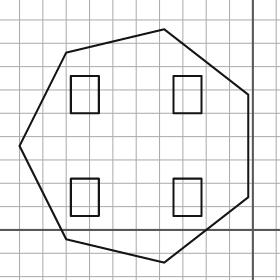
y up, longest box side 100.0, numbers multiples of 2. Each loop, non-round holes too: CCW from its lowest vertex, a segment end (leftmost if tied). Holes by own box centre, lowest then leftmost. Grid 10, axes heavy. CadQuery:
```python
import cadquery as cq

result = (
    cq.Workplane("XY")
    .moveTo(-38.0, -14.0)
    .lineTo(-2.0, 14.0)
    .lineTo(-2.0, 58.0)
    .lineTo(-38.0, 86.0)
    .lineTo(-80.0, 76.0)
    .lineTo(-100.0, 36.0)
    .lineTo(-80.0, -4.0)
    .close()
    .moveTo(-78.0, 6.0)
    .lineTo(-66.0, 6.0)
    .lineTo(-66.0, 22.0)
    .lineTo(-78.0, 22.0)
    .close()
    .moveTo(-34.0, 6.0)
    .lineTo(-22.0, 6.0)
    .lineTo(-22.0, 22.0)
    .lineTo(-34.0, 22.0)
    .close()
    .moveTo(-78.0, 50.0)
    .lineTo(-66.0, 50.0)
    .lineTo(-66.0, 66.0)
    .lineTo(-78.0, 66.0)
    .close()
    .moveTo(-34.0, 50.0)
    .lineTo(-22.0, 50.0)
    .lineTo(-22.0, 66.0)
    .lineTo(-34.0, 66.0)
    .close()
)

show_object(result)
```